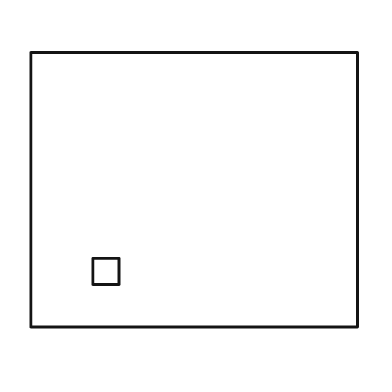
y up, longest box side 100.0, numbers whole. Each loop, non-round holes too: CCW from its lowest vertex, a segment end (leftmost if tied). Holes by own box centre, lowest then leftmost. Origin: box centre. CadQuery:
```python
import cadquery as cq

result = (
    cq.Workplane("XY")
    .moveTo(-50.0, -42.0)
    .lineTo(50.0, -42.0)
    .lineTo(50.0, 42.0)
    .lineTo(-50.0, 42.0)
    .close()
    .moveTo(-31.0, -29.0)
    .lineTo(-23.0, -29.0)
    .lineTo(-23.0, -21.0)
    .lineTo(-31.0, -21.0)
    .close()
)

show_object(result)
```